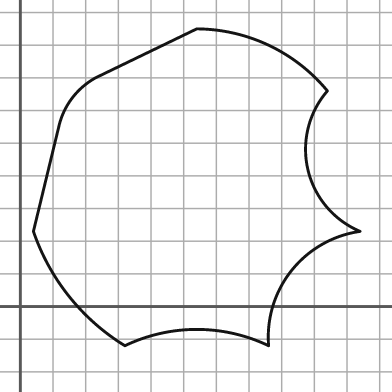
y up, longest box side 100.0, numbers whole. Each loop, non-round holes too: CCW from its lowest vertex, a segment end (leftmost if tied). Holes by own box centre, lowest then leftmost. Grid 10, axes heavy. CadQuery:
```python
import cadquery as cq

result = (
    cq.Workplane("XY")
    .moveTo(32.0, -12.0)
    .threePointArc((54.0, -7.0), (76.0, -12.0))
    .threePointArc((83.0, 11.0), (104.0, 23.0))
    .threePointArc((88.0, 42.0), (94.0, 66.0))
    .threePointArc((76.0, 80.0), (54.0, 85.0))
    .lineTo(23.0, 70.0)
    .threePointArc((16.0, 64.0), (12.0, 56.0))
    .lineTo(4.0, 23.0)
    .threePointArc((15.0, 3.0), (32.0, -12.0))
    .close()
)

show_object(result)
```